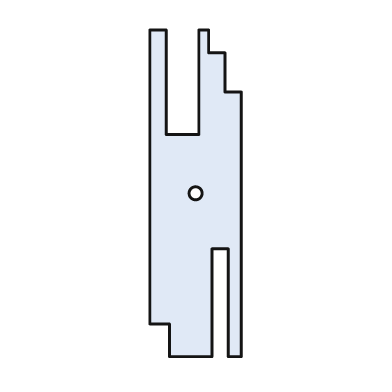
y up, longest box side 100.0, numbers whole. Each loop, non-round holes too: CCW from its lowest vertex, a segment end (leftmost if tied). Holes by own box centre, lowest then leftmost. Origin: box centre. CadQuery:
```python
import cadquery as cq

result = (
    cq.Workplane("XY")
    .moveTo(-8.0, -50.0)
    .lineTo(5.0, -50.0)
    .lineTo(5.0, -17.0)
    .lineTo(10.0, -17.0)
    .lineTo(10.0, -50.0)
    .lineTo(14.0, -50.0)
    .lineTo(14.0, 31.0)
    .lineTo(9.0, 31.0)
    .lineTo(9.0, 43.0)
    .lineTo(4.0, 43.0)
    .lineTo(4.0, 50.0)
    .lineTo(1.0, 50.0)
    .lineTo(1.0, 18.0)
    .lineTo(-9.0, 18.0)
    .lineTo(-9.0, 50.0)
    .lineTo(-14.0, 50.0)
    .lineTo(-14.0, -40.0)
    .lineTo(-8.0, -40.0)
    .close()
    .moveTo(0.0, 0.0)
    .circle(2.0)
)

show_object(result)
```